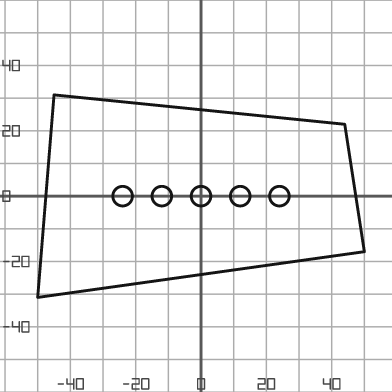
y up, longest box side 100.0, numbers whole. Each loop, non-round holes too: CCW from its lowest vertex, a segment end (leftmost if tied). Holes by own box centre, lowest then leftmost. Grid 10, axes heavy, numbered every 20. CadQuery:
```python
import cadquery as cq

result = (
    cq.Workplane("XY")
    .moveTo(-50.0, -31.0)
    .lineTo(50.0, -17.0)
    .lineTo(44.0, 22.0)
    .lineTo(-45.0, 31.0)
    .close()
    .moveTo(-24.0, 0.0)
    .circle(3.0)
    .moveTo(-12.0, 0.0)
    .circle(3.0)
    .moveTo(0.0, 0.0)
    .circle(3.0)
    .moveTo(12.0, 0.0)
    .circle(3.0)
    .moveTo(24.0, 0.0)
    .circle(3.0)
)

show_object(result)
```